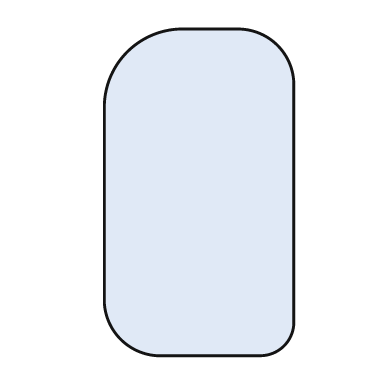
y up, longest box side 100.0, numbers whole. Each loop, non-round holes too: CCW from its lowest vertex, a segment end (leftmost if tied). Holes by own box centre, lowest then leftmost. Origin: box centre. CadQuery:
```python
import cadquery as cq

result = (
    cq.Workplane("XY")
    .moveTo(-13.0, -50.0)
    .lineTo(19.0, -50.0)
    .threePointArc((26.0, -47.0), (29.0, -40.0))
    .lineTo(29.0, 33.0)
    .threePointArc((24.0, 45.0), (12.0, 50.0))
    .lineTo(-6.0, 50.0)
    .threePointArc((-22.0, 43.0), (-29.0, 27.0))
    .lineTo(-29.0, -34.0)
    .threePointArc((-24.0, -45.0), (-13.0, -50.0))
    .close()
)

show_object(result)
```